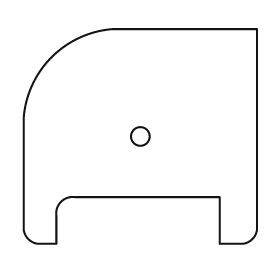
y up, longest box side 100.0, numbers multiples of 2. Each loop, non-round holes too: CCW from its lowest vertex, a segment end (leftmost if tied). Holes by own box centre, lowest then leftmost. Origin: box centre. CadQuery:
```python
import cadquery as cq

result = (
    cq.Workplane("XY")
    .moveTo(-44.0, -46.0)
    .lineTo(-36.0, -46.0)
    .lineTo(-36.0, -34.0)
    .threePointArc((-34.0, -28.0), (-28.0, -26.0))
    .lineTo(34.0, -26.0)
    .lineTo(34.0, -46.0)
    .lineTo(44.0, -46.0)
    .threePointArc((48.0, -44.0), (50.0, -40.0))
    .lineTo(50.0, 46.0)
    .lineTo(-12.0, 46.0)
    .threePointArc((-38.0, 34.0), (-50.0, 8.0))
    .lineTo(-50.0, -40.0)
    .threePointArc((-48.0, -44.0), (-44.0, -46.0))
    .close()
    .moveTo(0.0, 0.0)
    .circle(4.0)
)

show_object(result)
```